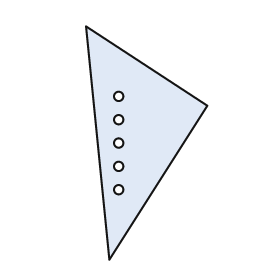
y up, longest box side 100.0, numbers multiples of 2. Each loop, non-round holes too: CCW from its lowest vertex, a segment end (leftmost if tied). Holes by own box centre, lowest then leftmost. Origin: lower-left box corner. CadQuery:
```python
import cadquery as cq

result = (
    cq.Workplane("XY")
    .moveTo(10.0, 0.0)
    .lineTo(52.0, 66.0)
    .lineTo(0.0, 100.0)
    .close()
    .moveTo(14.0, 30.0)
    .circle(2.0)
    .moveTo(14.0, 40.0)
    .circle(2.0)
    .moveTo(14.0, 50.0)
    .circle(2.0)
    .moveTo(14.0, 60.0)
    .circle(2.0)
    .moveTo(14.0, 70.0)
    .circle(2.0)
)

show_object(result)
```